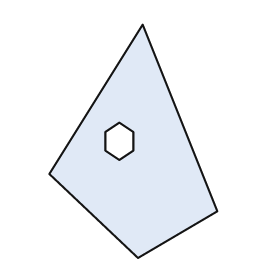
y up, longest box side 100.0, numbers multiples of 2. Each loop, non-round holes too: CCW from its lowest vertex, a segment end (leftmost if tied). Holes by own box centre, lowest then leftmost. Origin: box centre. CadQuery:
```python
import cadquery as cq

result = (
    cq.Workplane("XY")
    .moveTo(2.0, -50.0)
    .lineTo(36.0, -30.0)
    .lineTo(4.0, 50.0)
    .lineTo(-36.0, -14.0)
    .close()
    .moveTo(-6.0, -8.0)
    .lineTo(0.0, -4.0)
    .lineTo(0.0, 4.0)
    .lineTo(-6.0, 8.0)
    .lineTo(-12.0, 4.0)
    .lineTo(-12.0, -4.0)
    .close()
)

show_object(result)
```